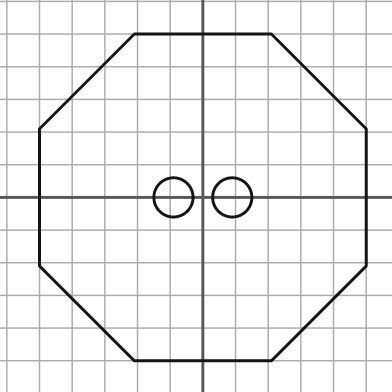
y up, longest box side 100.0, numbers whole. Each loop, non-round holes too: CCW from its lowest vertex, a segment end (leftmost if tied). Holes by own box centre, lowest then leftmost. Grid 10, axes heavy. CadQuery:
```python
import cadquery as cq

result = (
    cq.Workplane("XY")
    .moveTo(-21.0, -50.0)
    .lineTo(21.0, -50.0)
    .lineTo(50.0, -21.0)
    .lineTo(50.0, 21.0)
    .lineTo(21.0, 50.0)
    .lineTo(-21.0, 50.0)
    .lineTo(-50.0, 21.0)
    .lineTo(-50.0, -21.0)
    .close()
    .moveTo(-9.0, 0.0)
    .circle(6.0)
    .moveTo(9.0, 0.0)
    .circle(6.0)
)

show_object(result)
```